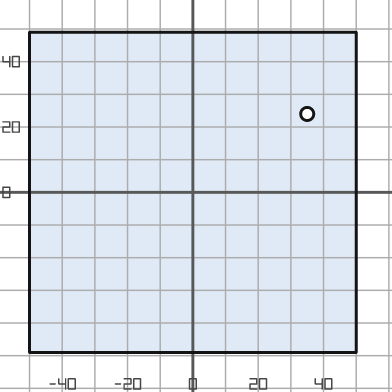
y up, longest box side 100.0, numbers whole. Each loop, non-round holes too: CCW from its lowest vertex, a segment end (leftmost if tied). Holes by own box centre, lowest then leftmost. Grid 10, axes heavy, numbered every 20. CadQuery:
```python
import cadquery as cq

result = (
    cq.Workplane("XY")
    .moveTo(-50.0, -49.0)
    .lineTo(50.0, -49.0)
    .lineTo(50.0, 49.0)
    .lineTo(-50.0, 49.0)
    .close()
    .moveTo(35.0, 24.0)
    .circle(2.0)
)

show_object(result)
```